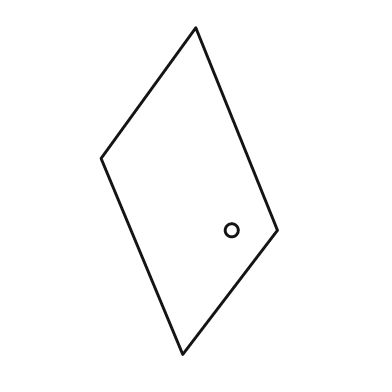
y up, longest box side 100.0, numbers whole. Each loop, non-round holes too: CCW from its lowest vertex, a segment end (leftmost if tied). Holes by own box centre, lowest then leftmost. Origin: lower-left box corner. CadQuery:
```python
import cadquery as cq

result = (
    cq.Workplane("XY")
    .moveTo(25.0, 0.0)
    .lineTo(54.0, 38.0)
    .lineTo(29.0, 100.0)
    .lineTo(0.0, 60.0)
    .close()
    .moveTo(40.0, 38.0)
    .circle(2.0)
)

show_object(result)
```